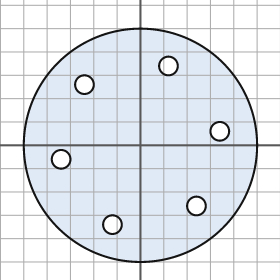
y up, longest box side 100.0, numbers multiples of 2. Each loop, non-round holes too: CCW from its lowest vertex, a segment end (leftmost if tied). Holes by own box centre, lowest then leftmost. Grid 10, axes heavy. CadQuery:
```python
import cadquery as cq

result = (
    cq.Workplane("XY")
    .moveTo(0.0, 0.0)
    .circle(50.0)
    .moveTo(-12.0, -34.0)
    .circle(4.0)
    .moveTo(24.0, -26.0)
    .circle(4.0)
    .moveTo(-34.0, -6.0)
    .circle(4.0)
    .moveTo(34.0, 6.0)
    .circle(4.0)
    .moveTo(-24.0, 26.0)
    .circle(4.0)
    .moveTo(12.0, 34.0)
    .circle(4.0)
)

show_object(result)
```